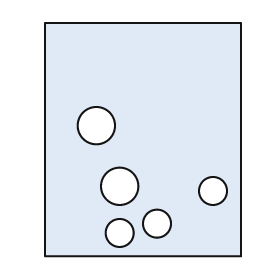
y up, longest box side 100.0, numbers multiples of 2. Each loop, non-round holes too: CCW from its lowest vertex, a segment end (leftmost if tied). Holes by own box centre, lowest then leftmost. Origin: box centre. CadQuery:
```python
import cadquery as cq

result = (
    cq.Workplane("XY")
    .moveTo(-42.0, -50.0)
    .lineTo(42.0, -50.0)
    .lineTo(42.0, 50.0)
    .lineTo(-42.0, 50.0)
    .close()
    .moveTo(-10.0, -40.0)
    .circle(6.0)
    .moveTo(6.0, -36.0)
    .circle(6.0)
    .moveTo(30.0, -22.0)
    .circle(6.0)
    .moveTo(-10.0, -20.0)
    .circle(8.0)
    .moveTo(-20.0, 6.0)
    .circle(8.0)
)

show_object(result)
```